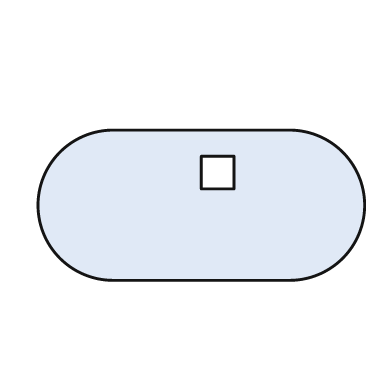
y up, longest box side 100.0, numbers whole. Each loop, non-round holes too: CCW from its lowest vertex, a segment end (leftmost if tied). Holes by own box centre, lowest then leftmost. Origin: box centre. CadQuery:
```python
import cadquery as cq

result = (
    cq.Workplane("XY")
    .moveTo(-27.0, -23.0)
    .lineTo(27.0, -23.0)
    .threePointArc((50.0, 0.0), (27.0, 23.0))
    .lineTo(-27.0, 23.0)
    .threePointArc((-50.0, 0.0), (-27.0, -23.0))
    .close()
    .moveTo(0.0, 5.0)
    .lineTo(10.0, 5.0)
    .lineTo(10.0, 15.0)
    .lineTo(0.0, 15.0)
    .close()
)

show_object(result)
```